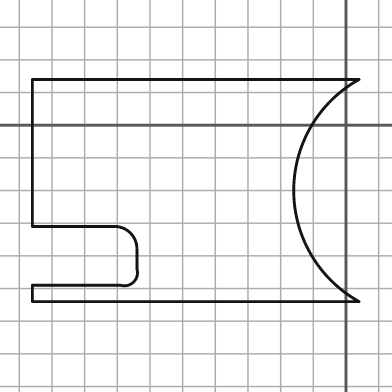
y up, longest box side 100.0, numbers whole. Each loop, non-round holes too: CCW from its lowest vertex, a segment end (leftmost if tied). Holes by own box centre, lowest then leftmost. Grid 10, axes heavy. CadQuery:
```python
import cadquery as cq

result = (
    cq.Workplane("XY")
    .moveTo(-96.0, -54.0)
    .lineTo(4.0, -54.0)
    .threePointArc((-16.0, -20.0), (4.0, 14.0))
    .lineTo(-96.0, 14.0)
    .lineTo(-96.0, -31.0)
    .lineTo(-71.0, -31.0)
    .threePointArc((-66.0, -33.0), (-64.0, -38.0))
    .lineTo(-64.0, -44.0)
    .threePointArc((-65.0, -48.0), (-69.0, -49.0))
    .lineTo(-96.0, -49.0)
    .close()
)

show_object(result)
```